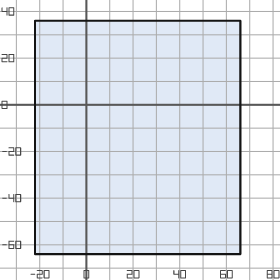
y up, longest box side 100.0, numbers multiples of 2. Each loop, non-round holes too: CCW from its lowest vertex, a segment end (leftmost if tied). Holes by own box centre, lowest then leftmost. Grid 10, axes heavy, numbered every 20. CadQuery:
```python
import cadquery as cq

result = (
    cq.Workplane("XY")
    .moveTo(-22.0, -64.0)
    .lineTo(66.0, -64.0)
    .lineTo(66.0, 36.0)
    .lineTo(-22.0, 36.0)
    .close()
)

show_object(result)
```